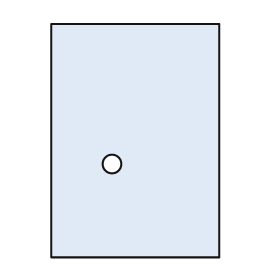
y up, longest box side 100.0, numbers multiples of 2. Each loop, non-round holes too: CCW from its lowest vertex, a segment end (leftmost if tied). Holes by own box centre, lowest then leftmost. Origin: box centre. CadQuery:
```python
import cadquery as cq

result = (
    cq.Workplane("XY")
    .moveTo(-36.0, -50.0)
    .lineTo(36.0, -50.0)
    .lineTo(36.0, 50.0)
    .lineTo(-36.0, 50.0)
    .close()
    .moveTo(-10.0, -10.0)
    .circle(4.0)
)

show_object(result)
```